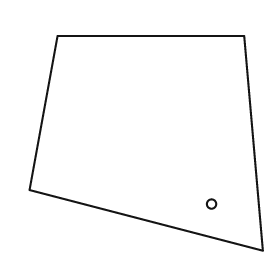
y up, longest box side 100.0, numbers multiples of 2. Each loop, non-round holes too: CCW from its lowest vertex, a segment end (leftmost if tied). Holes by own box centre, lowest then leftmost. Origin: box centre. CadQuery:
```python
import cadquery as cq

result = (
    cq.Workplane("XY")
    .moveTo(50.0, -46.0)
    .lineTo(42.0, 46.0)
    .lineTo(-38.0, 46.0)
    .lineTo(-50.0, -20.0)
    .close()
    .moveTo(28.0, -26.0)
    .circle(2.0)
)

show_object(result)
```